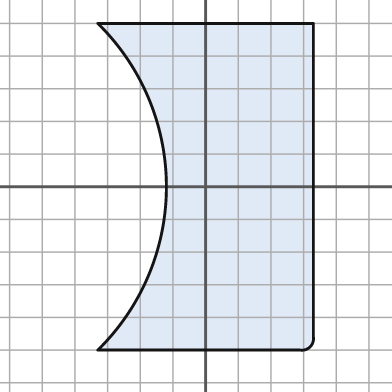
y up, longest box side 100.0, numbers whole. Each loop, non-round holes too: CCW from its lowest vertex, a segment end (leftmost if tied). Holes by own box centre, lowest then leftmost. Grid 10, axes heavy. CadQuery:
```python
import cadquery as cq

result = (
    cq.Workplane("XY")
    .moveTo(-33.0, -50.0)
    .lineTo(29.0, -50.0)
    .threePointArc((32.0, -49.0), (33.0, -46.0))
    .lineTo(33.0, 50.0)
    .lineTo(-33.0, 50.0)
    .threePointArc((-12.0, 0.0), (-33.0, -50.0))
    .close()
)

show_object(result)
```